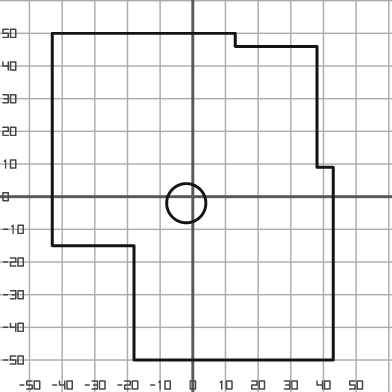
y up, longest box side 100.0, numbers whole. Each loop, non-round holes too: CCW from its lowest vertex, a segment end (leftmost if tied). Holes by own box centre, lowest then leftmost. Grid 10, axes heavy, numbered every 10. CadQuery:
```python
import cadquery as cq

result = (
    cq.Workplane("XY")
    .moveTo(-18.0, -50.0)
    .lineTo(43.0, -50.0)
    .lineTo(43.0, 9.0)
    .lineTo(38.0, 9.0)
    .lineTo(38.0, 46.0)
    .lineTo(13.0, 46.0)
    .lineTo(13.0, 50.0)
    .lineTo(-43.0, 50.0)
    .lineTo(-43.0, -15.0)
    .lineTo(-18.0, -15.0)
    .close()
    .moveTo(-2.0, -2.0)
    .circle(6.0)
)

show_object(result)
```